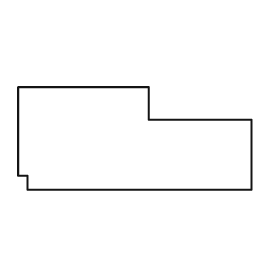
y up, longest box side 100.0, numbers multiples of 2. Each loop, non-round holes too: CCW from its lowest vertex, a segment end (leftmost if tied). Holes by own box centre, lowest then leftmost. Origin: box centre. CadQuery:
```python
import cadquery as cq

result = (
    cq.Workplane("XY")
    .moveTo(-46.0, -22.0)
    .lineTo(50.0, -22.0)
    .lineTo(50.0, 8.0)
    .lineTo(6.0, 8.0)
    .lineTo(6.0, 22.0)
    .lineTo(-50.0, 22.0)
    .lineTo(-50.0, -16.0)
    .lineTo(-46.0, -16.0)
    .close()
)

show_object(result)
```